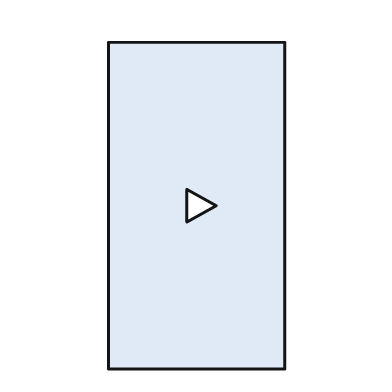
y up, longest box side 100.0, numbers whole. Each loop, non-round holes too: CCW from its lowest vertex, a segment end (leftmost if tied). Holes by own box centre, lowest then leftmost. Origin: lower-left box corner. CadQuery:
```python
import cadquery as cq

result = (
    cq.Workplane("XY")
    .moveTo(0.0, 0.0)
    .lineTo(54.0, 0.0)
    .lineTo(54.0, 100.0)
    .lineTo(0.0, 100.0)
    .close()
    .moveTo(24.0, 45.0)
    .lineTo(33.0, 50.0)
    .lineTo(24.0, 55.0)
    .close()
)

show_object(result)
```